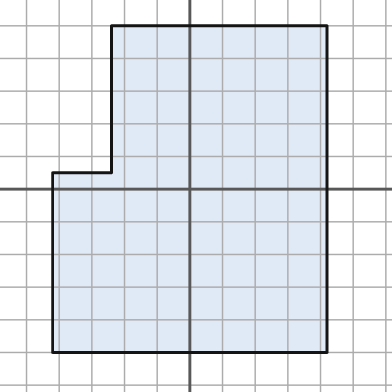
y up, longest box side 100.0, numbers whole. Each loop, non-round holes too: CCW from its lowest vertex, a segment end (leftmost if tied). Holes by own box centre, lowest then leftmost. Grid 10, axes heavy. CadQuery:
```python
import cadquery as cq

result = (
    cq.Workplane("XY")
    .moveTo(-42.0, -50.0)
    .lineTo(42.0, -50.0)
    .lineTo(42.0, 50.0)
    .lineTo(-24.0, 50.0)
    .lineTo(-24.0, 5.0)
    .lineTo(-42.0, 5.0)
    .close()
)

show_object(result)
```